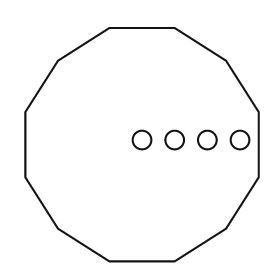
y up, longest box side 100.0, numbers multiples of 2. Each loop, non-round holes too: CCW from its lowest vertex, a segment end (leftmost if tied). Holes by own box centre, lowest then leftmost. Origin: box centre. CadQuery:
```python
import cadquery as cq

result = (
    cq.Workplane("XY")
    .moveTo(-14.0, -50.0)
    .lineTo(14.0, -50.0)
    .lineTo(36.0, -36.0)
    .lineTo(50.0, -14.0)
    .lineTo(50.0, 14.0)
    .lineTo(36.0, 36.0)
    .lineTo(14.0, 50.0)
    .lineTo(-14.0, 50.0)
    .lineTo(-36.0, 36.0)
    .lineTo(-50.0, 14.0)
    .lineTo(-50.0, -14.0)
    .lineTo(-36.0, -36.0)
    .close()
    .moveTo(0.0, 2.0)
    .circle(4.0)
    .moveTo(14.0, 2.0)
    .circle(4.0)
    .moveTo(28.0, 2.0)
    .circle(4.0)
    .moveTo(42.0, 2.0)
    .circle(4.0)
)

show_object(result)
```